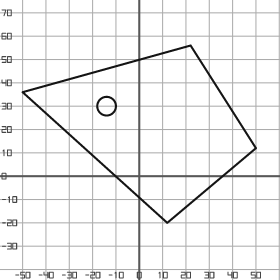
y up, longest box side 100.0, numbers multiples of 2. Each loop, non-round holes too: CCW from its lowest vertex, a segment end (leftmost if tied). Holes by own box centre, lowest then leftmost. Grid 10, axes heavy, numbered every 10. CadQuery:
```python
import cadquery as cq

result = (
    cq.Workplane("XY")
    .moveTo(12.0, -20.0)
    .lineTo(50.0, 12.0)
    .lineTo(22.0, 56.0)
    .lineTo(-50.0, 36.0)
    .close()
    .moveTo(-14.0, 30.0)
    .circle(4.0)
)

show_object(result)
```